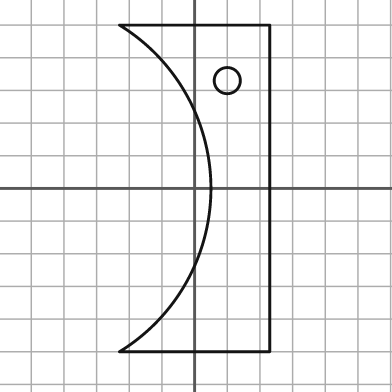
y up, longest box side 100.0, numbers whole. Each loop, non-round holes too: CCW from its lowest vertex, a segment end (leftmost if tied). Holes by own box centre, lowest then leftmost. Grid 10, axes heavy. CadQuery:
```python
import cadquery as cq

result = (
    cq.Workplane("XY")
    .moveTo(-23.0, -50.0)
    .lineTo(23.0, -50.0)
    .lineTo(23.0, 50.0)
    .lineTo(-23.0, 50.0)
    .threePointArc((5.0, 0.0), (-23.0, -50.0))
    .close()
    .moveTo(10.0, 33.0)
    .circle(4.0)
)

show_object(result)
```